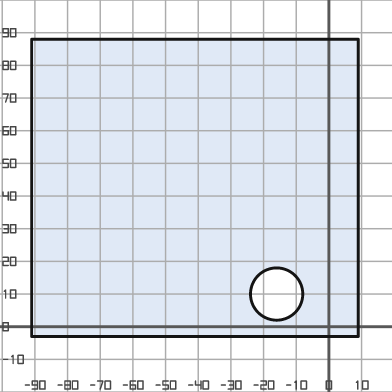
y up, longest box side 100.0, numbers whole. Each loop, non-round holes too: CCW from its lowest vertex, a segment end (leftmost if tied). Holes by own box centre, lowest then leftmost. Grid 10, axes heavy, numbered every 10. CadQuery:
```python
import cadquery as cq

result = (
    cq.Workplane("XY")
    .moveTo(-91.0, -3.0)
    .lineTo(9.0, -3.0)
    .lineTo(9.0, 88.0)
    .lineTo(-91.0, 88.0)
    .close()
    .moveTo(-16.0, 10.0)
    .circle(8.0)
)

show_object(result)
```